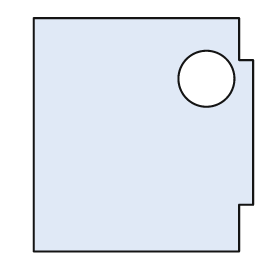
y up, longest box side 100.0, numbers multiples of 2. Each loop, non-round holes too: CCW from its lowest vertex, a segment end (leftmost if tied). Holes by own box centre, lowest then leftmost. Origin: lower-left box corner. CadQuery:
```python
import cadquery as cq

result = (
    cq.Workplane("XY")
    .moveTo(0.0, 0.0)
    .lineTo(88.0, 0.0)
    .lineTo(88.0, 20.0)
    .lineTo(94.0, 20.0)
    .lineTo(94.0, 82.0)
    .lineTo(88.0, 82.0)
    .lineTo(88.0, 100.0)
    .lineTo(0.0, 100.0)
    .close()
    .moveTo(74.0, 74.0)
    .circle(12.0)
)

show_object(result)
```